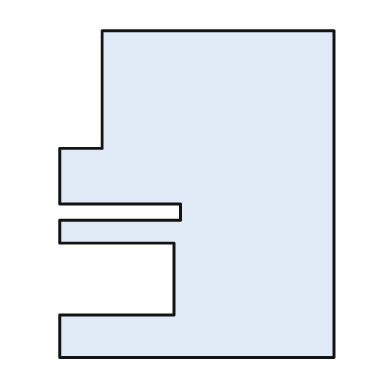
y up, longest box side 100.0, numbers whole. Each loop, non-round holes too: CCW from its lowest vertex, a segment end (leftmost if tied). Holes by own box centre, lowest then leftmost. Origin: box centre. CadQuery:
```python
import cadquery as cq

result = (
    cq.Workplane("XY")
    .moveTo(-42.0, -50.0)
    .lineTo(42.0, -50.0)
    .lineTo(42.0, 50.0)
    .lineTo(-29.0, 50.0)
    .lineTo(-29.0, 14.0)
    .lineTo(-42.0, 14.0)
    .lineTo(-42.0, -3.0)
    .lineTo(-5.0, -3.0)
    .lineTo(-5.0, -8.0)
    .lineTo(-42.0, -8.0)
    .lineTo(-42.0, -15.0)
    .lineTo(-7.0, -15.0)
    .lineTo(-7.0, -37.0)
    .lineTo(-42.0, -37.0)
    .close()
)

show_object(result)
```